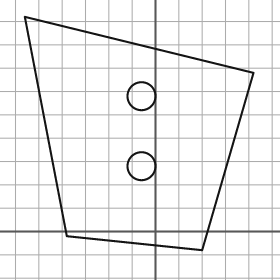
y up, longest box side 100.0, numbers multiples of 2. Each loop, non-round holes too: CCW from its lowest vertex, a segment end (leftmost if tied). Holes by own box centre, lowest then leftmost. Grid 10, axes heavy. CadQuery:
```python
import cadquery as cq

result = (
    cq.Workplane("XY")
    .moveTo(20.0, -8.0)
    .lineTo(42.0, 68.0)
    .lineTo(-56.0, 92.0)
    .lineTo(-38.0, -2.0)
    .close()
    .moveTo(-6.0, 28.0)
    .circle(6.0)
    .moveTo(-6.0, 58.0)
    .circle(6.0)
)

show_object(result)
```